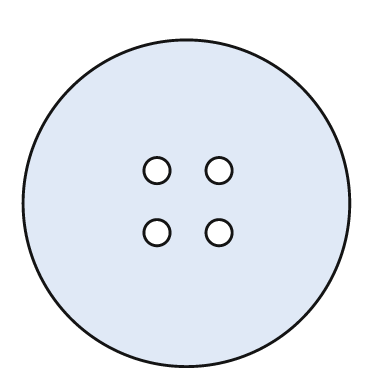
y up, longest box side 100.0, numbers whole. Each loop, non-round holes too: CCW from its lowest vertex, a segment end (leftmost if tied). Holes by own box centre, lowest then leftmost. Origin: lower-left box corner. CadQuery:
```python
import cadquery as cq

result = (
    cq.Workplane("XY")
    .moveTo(50.0, 50.0)
    .circle(50.0)
    .moveTo(41.0, 41.0)
    .circle(4.0)
    .moveTo(60.0, 41.0)
    .circle(4.0)
    .moveTo(41.0, 60.0)
    .circle(4.0)
    .moveTo(60.0, 60.0)
    .circle(4.0)
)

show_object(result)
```